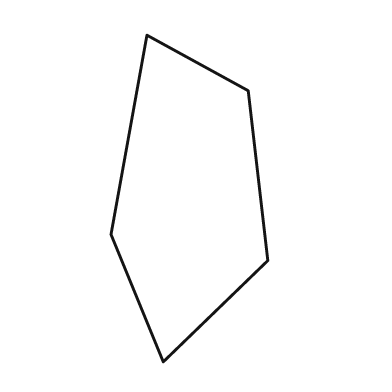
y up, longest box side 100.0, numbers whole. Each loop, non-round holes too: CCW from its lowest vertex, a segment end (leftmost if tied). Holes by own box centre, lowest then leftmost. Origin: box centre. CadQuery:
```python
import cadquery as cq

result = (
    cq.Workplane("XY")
    .moveTo(-8.0, -50.0)
    .lineTo(24.0, -19.0)
    .lineTo(18.0, 33.0)
    .lineTo(-13.0, 50.0)
    .lineTo(-24.0, -11.0)
    .close()
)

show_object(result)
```